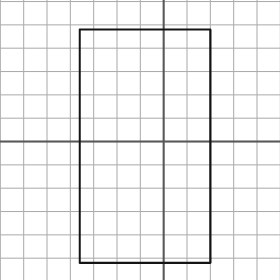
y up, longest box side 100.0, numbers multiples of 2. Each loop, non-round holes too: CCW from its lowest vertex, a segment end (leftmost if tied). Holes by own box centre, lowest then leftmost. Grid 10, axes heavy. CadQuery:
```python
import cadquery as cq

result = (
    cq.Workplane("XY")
    .moveTo(-36.0, -52.0)
    .lineTo(20.0, -52.0)
    .lineTo(20.0, 48.0)
    .lineTo(-36.0, 48.0)
    .close()
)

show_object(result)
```